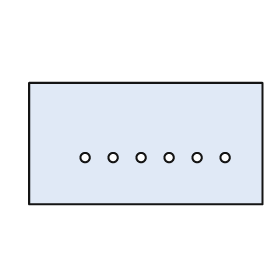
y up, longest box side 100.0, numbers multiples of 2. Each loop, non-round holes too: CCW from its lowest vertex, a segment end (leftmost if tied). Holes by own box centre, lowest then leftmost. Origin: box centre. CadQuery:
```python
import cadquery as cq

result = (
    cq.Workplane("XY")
    .moveTo(-50.0, -26.0)
    .lineTo(50.0, -26.0)
    .lineTo(50.0, 26.0)
    .lineTo(-50.0, 26.0)
    .close()
    .moveTo(-26.0, -6.0)
    .circle(2.0)
    .moveTo(-14.0, -6.0)
    .circle(2.0)
    .moveTo(-2.0, -6.0)
    .circle(2.0)
    .moveTo(10.0, -6.0)
    .circle(2.0)
    .moveTo(22.0, -6.0)
    .circle(2.0)
    .moveTo(34.0, -6.0)
    .circle(2.0)
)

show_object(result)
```